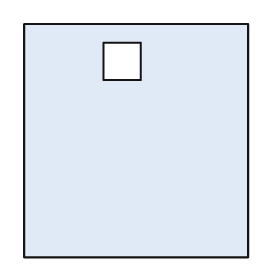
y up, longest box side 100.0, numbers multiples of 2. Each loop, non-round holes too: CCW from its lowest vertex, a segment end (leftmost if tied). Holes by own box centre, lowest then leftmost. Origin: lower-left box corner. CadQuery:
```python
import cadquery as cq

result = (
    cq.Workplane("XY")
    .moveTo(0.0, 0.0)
    .lineTo(96.0, 0.0)
    .lineTo(96.0, 100.0)
    .lineTo(0.0, 100.0)
    .close()
    .moveTo(34.0, 76.0)
    .lineTo(50.0, 76.0)
    .lineTo(50.0, 92.0)
    .lineTo(34.0, 92.0)
    .close()
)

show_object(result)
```